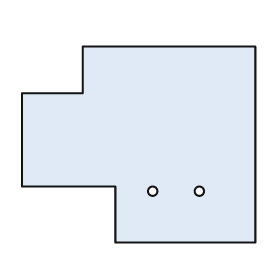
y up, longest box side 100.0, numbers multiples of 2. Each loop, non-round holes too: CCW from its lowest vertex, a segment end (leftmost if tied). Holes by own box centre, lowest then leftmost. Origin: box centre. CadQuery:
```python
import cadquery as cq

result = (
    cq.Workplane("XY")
    .moveTo(-10.0, -42.0)
    .lineTo(50.0, -42.0)
    .lineTo(50.0, 42.0)
    .lineTo(-24.0, 42.0)
    .lineTo(-24.0, 22.0)
    .lineTo(-50.0, 22.0)
    .lineTo(-50.0, -18.0)
    .lineTo(-10.0, -18.0)
    .close()
    .moveTo(6.0, -20.0)
    .circle(2.0)
    .moveTo(26.0, -20.0)
    .circle(2.0)
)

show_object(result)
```